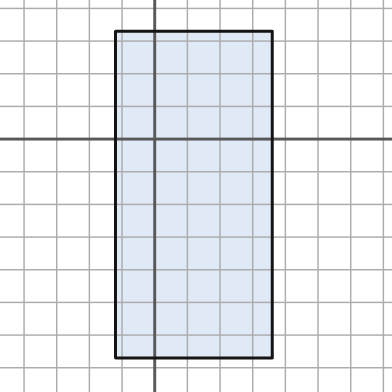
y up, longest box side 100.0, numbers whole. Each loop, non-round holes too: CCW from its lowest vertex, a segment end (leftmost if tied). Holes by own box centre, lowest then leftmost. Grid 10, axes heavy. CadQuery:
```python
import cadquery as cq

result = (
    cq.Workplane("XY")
    .moveTo(-12.0, -67.0)
    .lineTo(36.0, -67.0)
    .lineTo(36.0, 33.0)
    .lineTo(-12.0, 33.0)
    .close()
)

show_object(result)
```